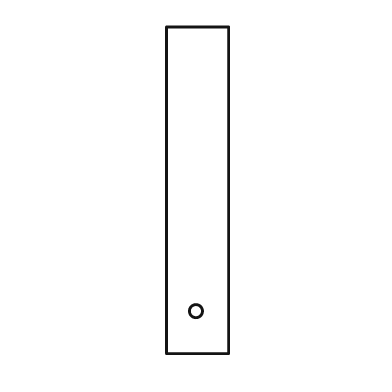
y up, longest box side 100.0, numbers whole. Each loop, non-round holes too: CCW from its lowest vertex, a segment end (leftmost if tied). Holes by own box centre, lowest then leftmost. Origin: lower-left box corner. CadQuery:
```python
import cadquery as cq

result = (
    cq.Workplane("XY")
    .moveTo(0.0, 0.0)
    .lineTo(19.0, 0.0)
    .lineTo(19.0, 100.0)
    .lineTo(0.0, 100.0)
    .close()
    .moveTo(9.0, 13.0)
    .circle(2.0)
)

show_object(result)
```